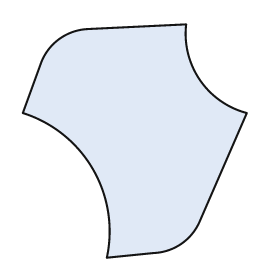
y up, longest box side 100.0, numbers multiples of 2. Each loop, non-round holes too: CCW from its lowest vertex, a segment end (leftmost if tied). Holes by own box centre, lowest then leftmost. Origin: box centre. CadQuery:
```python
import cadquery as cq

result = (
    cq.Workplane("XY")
    .moveTo(-12.0, -50.0)
    .lineTo(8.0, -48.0)
    .threePointArc((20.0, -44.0), (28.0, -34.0))
    .lineTo(48.0, 12.0)
    .threePointArc((28.0, 26.0), (22.0, 50.0))
    .lineTo(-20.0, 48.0)
    .threePointArc((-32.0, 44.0), (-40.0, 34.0))
    .lineTo(-48.0, 12.0)
    .threePointArc((-18.0, -12.0), (-12.0, -50.0))
    .close()
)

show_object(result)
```